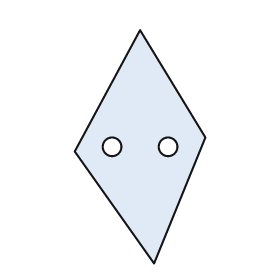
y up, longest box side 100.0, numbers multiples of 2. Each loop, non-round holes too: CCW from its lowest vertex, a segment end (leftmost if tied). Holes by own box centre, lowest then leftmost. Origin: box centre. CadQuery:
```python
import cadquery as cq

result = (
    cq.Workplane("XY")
    .moveTo(6.0, -50.0)
    .lineTo(28.0, 4.0)
    .lineTo(0.0, 50.0)
    .lineTo(-28.0, -2.0)
    .close()
    .moveTo(-12.0, 0.0)
    .circle(4.0)
    .moveTo(12.0, 0.0)
    .circle(4.0)
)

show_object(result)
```